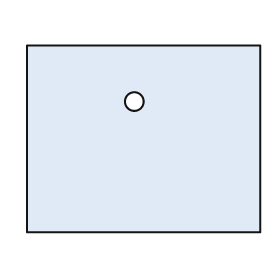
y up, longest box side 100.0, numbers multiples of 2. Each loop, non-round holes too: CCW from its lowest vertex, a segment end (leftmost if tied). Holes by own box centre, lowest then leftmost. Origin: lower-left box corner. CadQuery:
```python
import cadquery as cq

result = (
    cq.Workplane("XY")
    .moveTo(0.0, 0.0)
    .lineTo(100.0, 0.0)
    .lineTo(100.0, 80.0)
    .lineTo(0.0, 80.0)
    .close()
    .moveTo(46.0, 56.0)
    .circle(4.0)
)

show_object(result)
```